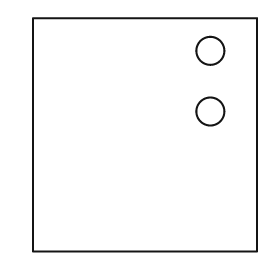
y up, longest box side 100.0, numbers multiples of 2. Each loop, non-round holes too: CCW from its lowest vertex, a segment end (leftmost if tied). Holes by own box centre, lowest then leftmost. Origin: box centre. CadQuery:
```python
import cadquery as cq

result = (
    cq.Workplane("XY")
    .moveTo(-48.0, -50.0)
    .lineTo(48.0, -50.0)
    .lineTo(48.0, 50.0)
    .lineTo(-48.0, 50.0)
    .close()
    .moveTo(28.0, 10.0)
    .circle(6.0)
    .moveTo(28.0, 36.0)
    .circle(6.0)
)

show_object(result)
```